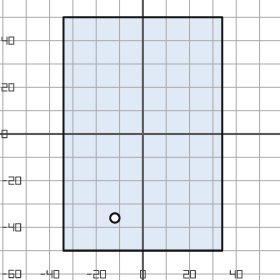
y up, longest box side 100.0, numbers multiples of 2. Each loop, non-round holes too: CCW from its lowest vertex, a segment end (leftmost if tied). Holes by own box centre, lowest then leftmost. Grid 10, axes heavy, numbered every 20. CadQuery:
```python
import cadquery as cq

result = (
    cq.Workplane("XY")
    .moveTo(-34.0, -50.0)
    .lineTo(34.0, -50.0)
    .lineTo(34.0, 50.0)
    .lineTo(-34.0, 50.0)
    .close()
    .moveTo(-12.0, -36.0)
    .circle(2.0)
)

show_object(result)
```